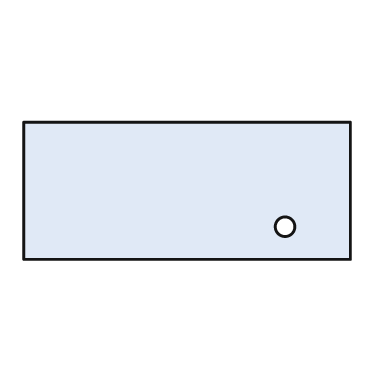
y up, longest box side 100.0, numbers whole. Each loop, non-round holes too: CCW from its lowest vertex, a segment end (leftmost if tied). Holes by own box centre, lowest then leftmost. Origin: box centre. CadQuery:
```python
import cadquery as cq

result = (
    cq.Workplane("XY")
    .moveTo(-50.0, -21.0)
    .lineTo(50.0, -21.0)
    .lineTo(50.0, 21.0)
    .lineTo(-50.0, 21.0)
    .close()
    .moveTo(30.0, -11.0)
    .circle(3.0)
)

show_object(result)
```